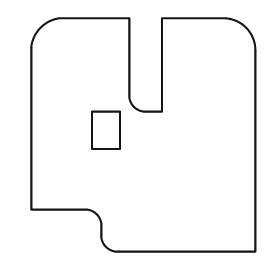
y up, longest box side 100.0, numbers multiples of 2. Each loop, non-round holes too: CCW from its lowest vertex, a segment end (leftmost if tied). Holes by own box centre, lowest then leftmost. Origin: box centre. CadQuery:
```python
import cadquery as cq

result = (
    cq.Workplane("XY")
    .moveTo(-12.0, -50.0)
    .lineTo(48.0, -50.0)
    .lineTo(48.0, 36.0)
    .threePointArc((44.0, 46.0), (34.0, 50.0))
    .lineTo(8.0, 50.0)
    .lineTo(8.0, 10.0)
    .lineTo(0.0, 10.0)
    .threePointArc((-4.0, 12.0), (-6.0, 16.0))
    .lineTo(-6.0, 50.0)
    .lineTo(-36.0, 50.0)
    .threePointArc((-44.0, 46.0), (-48.0, 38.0))
    .lineTo(-48.0, -32.0)
    .lineTo(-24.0, -32.0)
    .threePointArc((-20.0, -34.0), (-18.0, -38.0))
    .lineTo(-18.0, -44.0)
    .threePointArc((-16.0, -48.0), (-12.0, -50.0))
    .close()
    .moveTo(-22.0, -6.0)
    .lineTo(-10.0, -6.0)
    .lineTo(-10.0, 10.0)
    .lineTo(-22.0, 10.0)
    .close()
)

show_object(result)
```